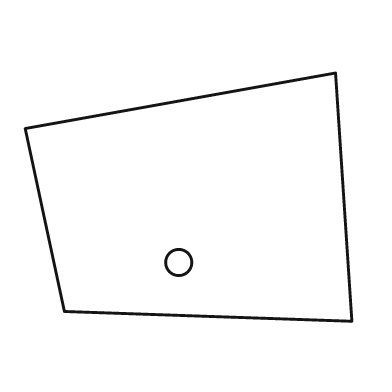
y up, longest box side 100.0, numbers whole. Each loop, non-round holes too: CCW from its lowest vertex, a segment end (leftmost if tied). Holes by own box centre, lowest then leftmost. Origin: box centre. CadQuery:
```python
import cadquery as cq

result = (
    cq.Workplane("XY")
    .moveTo(50.0, -38.0)
    .lineTo(45.0, 38.0)
    .lineTo(-50.0, 21.0)
    .lineTo(-38.0, -35.0)
    .close()
    .moveTo(-3.0, -20.0)
    .circle(4.0)
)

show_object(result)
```